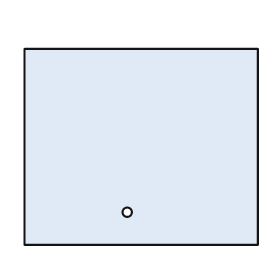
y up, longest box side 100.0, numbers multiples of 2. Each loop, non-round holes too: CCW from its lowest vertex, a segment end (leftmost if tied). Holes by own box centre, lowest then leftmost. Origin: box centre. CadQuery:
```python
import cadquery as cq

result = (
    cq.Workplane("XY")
    .moveTo(-50.0, -42.0)
    .lineTo(50.0, -42.0)
    .lineTo(50.0, 42.0)
    .lineTo(-50.0, 42.0)
    .close()
    .moveTo(-6.0, -28.0)
    .circle(2.0)
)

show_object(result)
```